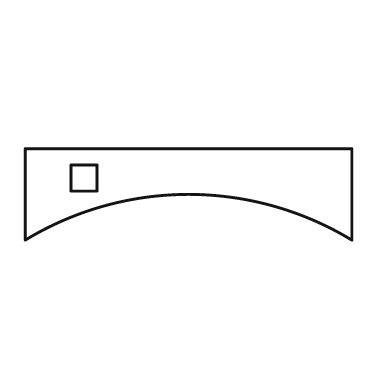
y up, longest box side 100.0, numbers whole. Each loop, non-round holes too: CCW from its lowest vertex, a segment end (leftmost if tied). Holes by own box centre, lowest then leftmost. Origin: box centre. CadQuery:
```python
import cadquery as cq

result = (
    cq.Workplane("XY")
    .moveTo(-50.0, -14.0)
    .threePointArc((0.0, 0.0), (50.0, -14.0))
    .lineTo(50.0, 14.0)
    .lineTo(-50.0, 14.0)
    .close()
    .moveTo(-36.0, 1.0)
    .lineTo(-28.0, 1.0)
    .lineTo(-28.0, 9.0)
    .lineTo(-36.0, 9.0)
    .close()
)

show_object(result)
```